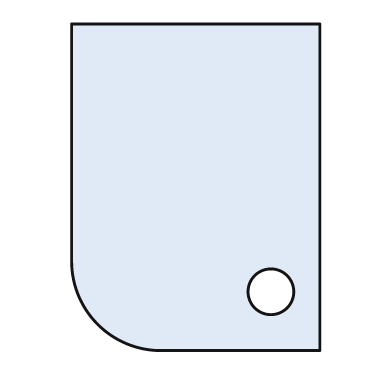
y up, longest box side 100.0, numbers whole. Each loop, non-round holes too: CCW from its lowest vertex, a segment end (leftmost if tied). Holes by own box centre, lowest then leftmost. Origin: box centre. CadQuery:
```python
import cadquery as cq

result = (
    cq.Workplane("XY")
    .moveTo(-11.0, -50.0)
    .lineTo(38.0, -50.0)
    .lineTo(38.0, 50.0)
    .lineTo(-38.0, 50.0)
    .lineTo(-38.0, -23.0)
    .threePointArc((-30.0, -42.0), (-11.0, -50.0))
    .close()
    .moveTo(23.0, -32.0)
    .circle(7.0)
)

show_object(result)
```